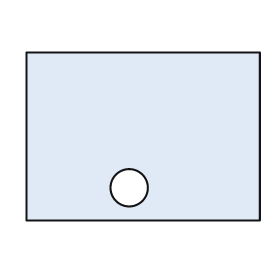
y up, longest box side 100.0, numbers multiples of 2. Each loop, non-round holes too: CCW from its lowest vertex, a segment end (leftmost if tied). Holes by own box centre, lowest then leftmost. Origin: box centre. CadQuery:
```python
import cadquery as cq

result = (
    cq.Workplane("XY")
    .moveTo(-50.0, -36.0)
    .lineTo(50.0, -36.0)
    .lineTo(50.0, 36.0)
    .lineTo(-50.0, 36.0)
    .close()
    .moveTo(-6.0, -22.0)
    .circle(8.0)
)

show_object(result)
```